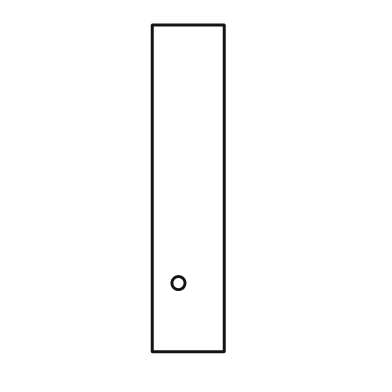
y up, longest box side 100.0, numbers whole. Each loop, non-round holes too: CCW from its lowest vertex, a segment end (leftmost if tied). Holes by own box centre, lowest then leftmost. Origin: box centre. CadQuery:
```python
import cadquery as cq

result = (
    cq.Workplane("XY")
    .moveTo(-11.0, -50.0)
    .lineTo(11.0, -50.0)
    .lineTo(11.0, 50.0)
    .lineTo(-11.0, 50.0)
    .close()
    .moveTo(-3.0, -29.0)
    .circle(2.0)
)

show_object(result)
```